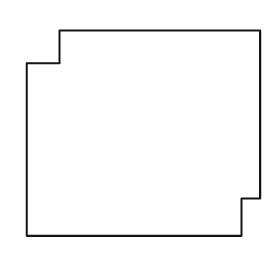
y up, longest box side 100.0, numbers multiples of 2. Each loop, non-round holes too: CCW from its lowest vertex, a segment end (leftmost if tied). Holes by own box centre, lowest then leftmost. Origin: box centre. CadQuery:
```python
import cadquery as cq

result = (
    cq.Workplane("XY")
    .moveTo(-50.0, -44.0)
    .lineTo(42.0, -44.0)
    .lineTo(42.0, -28.0)
    .lineTo(50.0, -28.0)
    .lineTo(50.0, 44.0)
    .lineTo(-36.0, 44.0)
    .lineTo(-36.0, 30.0)
    .lineTo(-50.0, 30.0)
    .close()
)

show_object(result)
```